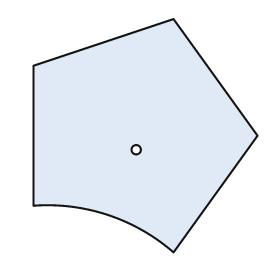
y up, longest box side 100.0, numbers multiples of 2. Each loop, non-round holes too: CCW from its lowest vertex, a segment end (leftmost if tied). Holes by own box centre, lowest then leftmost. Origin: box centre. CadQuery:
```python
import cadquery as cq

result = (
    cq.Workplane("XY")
    .moveTo(12.0, -50.0)
    .lineTo(48.0, 0.0)
    .lineTo(12.0, 50.0)
    .lineTo(-48.0, 30.0)
    .lineTo(-48.0, -30.0)
    .threePointArc((-16.0, -34.0), (12.0, -50.0))
    .close()
    .moveTo(-4.0, -6.0)
    .circle(2.0)
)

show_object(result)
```